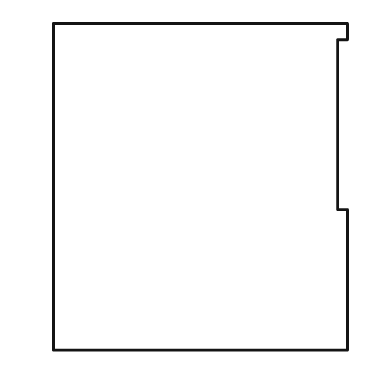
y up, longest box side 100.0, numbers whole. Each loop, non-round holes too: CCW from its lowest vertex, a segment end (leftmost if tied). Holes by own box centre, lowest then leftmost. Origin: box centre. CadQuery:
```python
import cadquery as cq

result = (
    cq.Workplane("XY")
    .moveTo(-45.0, -50.0)
    .lineTo(45.0, -50.0)
    .lineTo(45.0, -7.0)
    .lineTo(42.0, -7.0)
    .lineTo(42.0, 45.0)
    .lineTo(45.0, 45.0)
    .lineTo(45.0, 50.0)
    .lineTo(-45.0, 50.0)
    .close()
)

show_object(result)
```